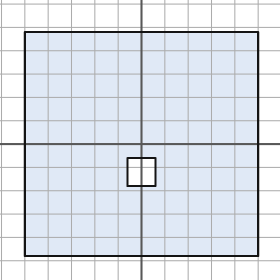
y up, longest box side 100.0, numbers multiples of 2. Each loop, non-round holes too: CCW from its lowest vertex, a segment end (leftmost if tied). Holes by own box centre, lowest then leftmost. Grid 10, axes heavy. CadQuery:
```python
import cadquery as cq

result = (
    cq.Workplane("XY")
    .moveTo(-50.0, -48.0)
    .lineTo(50.0, -48.0)
    .lineTo(50.0, 48.0)
    .lineTo(-50.0, 48.0)
    .close()
    .moveTo(-6.0, -18.0)
    .lineTo(6.0, -18.0)
    .lineTo(6.0, -6.0)
    .lineTo(-6.0, -6.0)
    .close()
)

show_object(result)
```